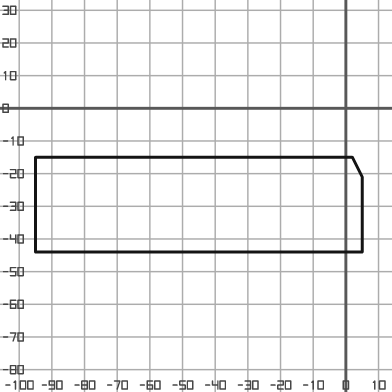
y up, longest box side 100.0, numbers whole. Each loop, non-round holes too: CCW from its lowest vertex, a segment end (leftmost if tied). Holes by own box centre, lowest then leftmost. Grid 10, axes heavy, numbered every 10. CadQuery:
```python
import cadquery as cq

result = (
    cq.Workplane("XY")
    .moveTo(-95.0, -44.0)
    .lineTo(5.0, -44.0)
    .lineTo(5.0, -21.0)
    .lineTo(2.0, -15.0)
    .lineTo(-95.0, -15.0)
    .close()
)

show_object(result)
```